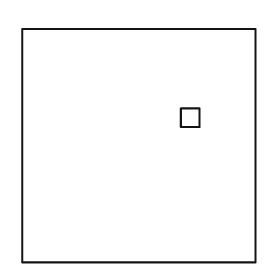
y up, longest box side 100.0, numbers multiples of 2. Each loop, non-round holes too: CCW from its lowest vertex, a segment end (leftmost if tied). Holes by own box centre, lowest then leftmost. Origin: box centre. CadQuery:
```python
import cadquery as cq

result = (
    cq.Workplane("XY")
    .moveTo(-50.0, -50.0)
    .lineTo(50.0, -50.0)
    .lineTo(50.0, 50.0)
    .lineTo(-50.0, 50.0)
    .close()
    .moveTo(18.0, 8.0)
    .lineTo(26.0, 8.0)
    .lineTo(26.0, 16.0)
    .lineTo(18.0, 16.0)
    .close()
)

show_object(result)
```